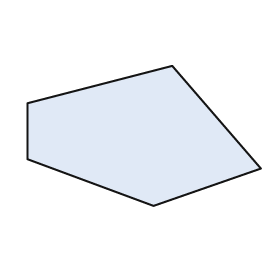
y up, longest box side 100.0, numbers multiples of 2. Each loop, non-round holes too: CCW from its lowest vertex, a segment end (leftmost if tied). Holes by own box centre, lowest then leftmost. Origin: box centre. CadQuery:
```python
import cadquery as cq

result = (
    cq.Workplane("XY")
    .moveTo(4.0, -30.0)
    .lineTo(50.0, -14.0)
    .lineTo(12.0, 30.0)
    .lineTo(-50.0, 14.0)
    .lineTo(-50.0, -10.0)
    .close()
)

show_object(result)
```